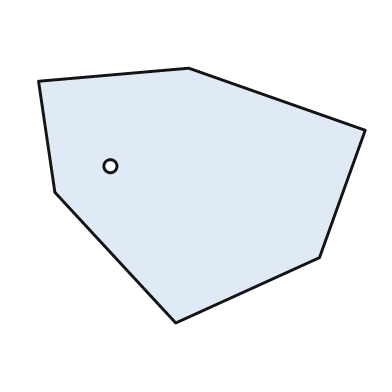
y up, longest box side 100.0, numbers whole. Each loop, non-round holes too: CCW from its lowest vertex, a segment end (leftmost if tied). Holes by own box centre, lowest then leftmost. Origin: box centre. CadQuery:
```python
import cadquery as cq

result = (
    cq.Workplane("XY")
    .moveTo(-8.0, -39.0)
    .lineTo(36.0, -19.0)
    .lineTo(50.0, 20.0)
    .lineTo(-4.0, 39.0)
    .lineTo(-50.0, 35.0)
    .lineTo(-45.0, 1.0)
    .close()
    .moveTo(-28.0, 9.0)
    .circle(2.0)
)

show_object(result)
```